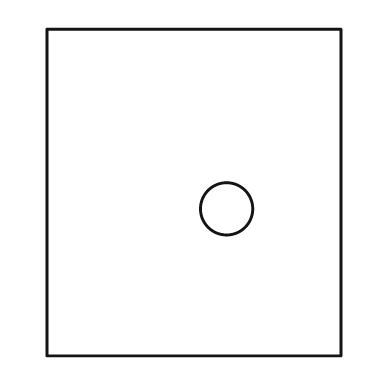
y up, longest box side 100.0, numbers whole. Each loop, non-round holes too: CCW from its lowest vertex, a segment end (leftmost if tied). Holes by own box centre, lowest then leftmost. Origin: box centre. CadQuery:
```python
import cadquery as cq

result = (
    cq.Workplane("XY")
    .moveTo(-45.0, -50.0)
    .lineTo(45.0, -50.0)
    .lineTo(45.0, 50.0)
    .lineTo(-45.0, 50.0)
    .close()
    .moveTo(10.0, -5.0)
    .circle(8.0)
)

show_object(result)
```